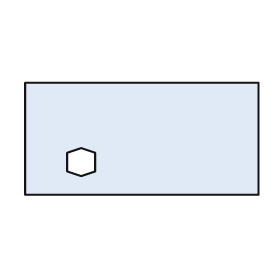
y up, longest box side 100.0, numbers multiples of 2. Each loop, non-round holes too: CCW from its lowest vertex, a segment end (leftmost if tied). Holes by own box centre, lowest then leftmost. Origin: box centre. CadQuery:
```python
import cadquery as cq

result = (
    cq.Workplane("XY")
    .moveTo(-50.0, -24.0)
    .lineTo(50.0, -24.0)
    .lineTo(50.0, 24.0)
    .lineTo(-50.0, 24.0)
    .close()
    .moveTo(-26.0, -16.0)
    .lineTo(-20.0, -14.0)
    .lineTo(-20.0, -6.0)
    .lineTo(-26.0, -4.0)
    .lineTo(-32.0, -6.0)
    .lineTo(-32.0, -14.0)
    .close()
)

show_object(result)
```